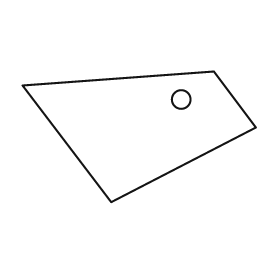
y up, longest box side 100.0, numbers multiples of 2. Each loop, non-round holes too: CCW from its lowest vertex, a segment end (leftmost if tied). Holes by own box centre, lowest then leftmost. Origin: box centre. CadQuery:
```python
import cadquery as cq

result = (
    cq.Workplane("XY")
    .moveTo(-12.0, -28.0)
    .lineTo(50.0, 4.0)
    .lineTo(32.0, 28.0)
    .lineTo(-50.0, 22.0)
    .close()
    .moveTo(18.0, 16.0)
    .circle(4.0)
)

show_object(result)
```